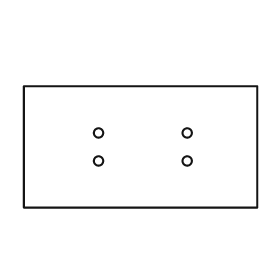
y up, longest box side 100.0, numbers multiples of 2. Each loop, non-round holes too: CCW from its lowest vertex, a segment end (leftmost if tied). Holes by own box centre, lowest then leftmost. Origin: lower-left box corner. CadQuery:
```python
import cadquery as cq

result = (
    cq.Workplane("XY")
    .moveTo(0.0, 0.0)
    .lineTo(100.0, 0.0)
    .lineTo(100.0, 52.0)
    .lineTo(0.0, 52.0)
    .close()
    .moveTo(32.0, 20.0)
    .circle(2.0)
    .moveTo(70.0, 20.0)
    .circle(2.0)
    .moveTo(32.0, 32.0)
    .circle(2.0)
    .moveTo(70.0, 32.0)
    .circle(2.0)
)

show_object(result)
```